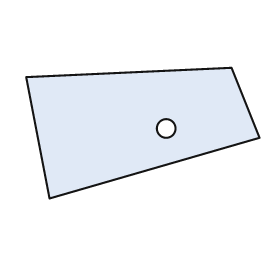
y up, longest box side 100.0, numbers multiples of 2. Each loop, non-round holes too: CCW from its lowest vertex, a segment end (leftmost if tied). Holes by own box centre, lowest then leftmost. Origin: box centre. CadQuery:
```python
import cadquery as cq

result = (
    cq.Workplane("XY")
    .moveTo(-40.0, -28.0)
    .lineTo(50.0, -2.0)
    .lineTo(38.0, 28.0)
    .lineTo(-50.0, 24.0)
    .close()
    .moveTo(10.0, 2.0)
    .circle(4.0)
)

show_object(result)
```